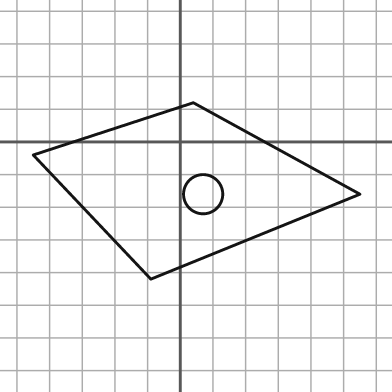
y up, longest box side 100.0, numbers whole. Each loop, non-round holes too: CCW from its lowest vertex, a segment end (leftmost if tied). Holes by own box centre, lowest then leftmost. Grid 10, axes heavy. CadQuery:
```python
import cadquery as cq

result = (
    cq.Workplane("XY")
    .moveTo(-9.0, -42.0)
    .lineTo(55.0, -16.0)
    .lineTo(4.0, 12.0)
    .lineTo(-45.0, -4.0)
    .close()
    .moveTo(7.0, -16.0)
    .circle(6.0)
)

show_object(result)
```